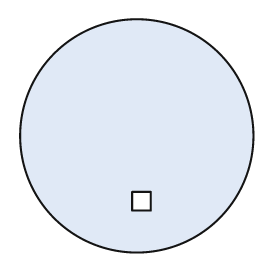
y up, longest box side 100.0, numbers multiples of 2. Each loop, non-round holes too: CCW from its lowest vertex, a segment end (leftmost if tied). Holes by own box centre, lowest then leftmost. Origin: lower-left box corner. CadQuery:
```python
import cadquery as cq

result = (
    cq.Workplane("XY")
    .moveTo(50.0, 50.0)
    .circle(50.0)
    .moveTo(48.0, 18.0)
    .lineTo(56.0, 18.0)
    .lineTo(56.0, 26.0)
    .lineTo(48.0, 26.0)
    .close()
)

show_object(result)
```